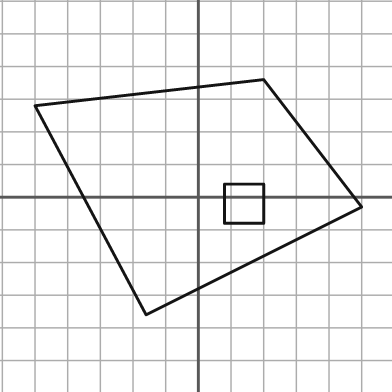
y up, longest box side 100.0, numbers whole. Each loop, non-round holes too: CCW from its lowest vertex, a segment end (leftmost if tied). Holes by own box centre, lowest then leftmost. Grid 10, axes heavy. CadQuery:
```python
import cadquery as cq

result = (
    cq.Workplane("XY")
    .moveTo(-16.0, -36.0)
    .lineTo(50.0, -3.0)
    .lineTo(20.0, 36.0)
    .lineTo(-50.0, 28.0)
    .close()
    .moveTo(8.0, -8.0)
    .lineTo(20.0, -8.0)
    .lineTo(20.0, 4.0)
    .lineTo(8.0, 4.0)
    .close()
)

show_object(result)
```